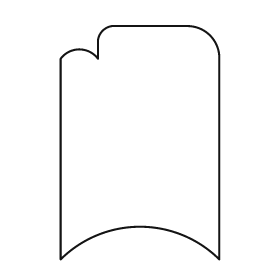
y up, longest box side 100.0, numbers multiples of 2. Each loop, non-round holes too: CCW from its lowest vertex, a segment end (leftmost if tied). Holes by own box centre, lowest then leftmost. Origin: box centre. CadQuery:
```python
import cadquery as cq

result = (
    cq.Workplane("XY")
    .moveTo(-34.0, -50.0)
    .threePointArc((0.0, -36.0), (34.0, -50.0))
    .lineTo(34.0, 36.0)
    .threePointArc((30.0, 46.0), (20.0, 50.0))
    .lineTo(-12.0, 50.0)
    .threePointArc((-16.0, 48.0), (-18.0, 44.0))
    .lineTo(-18.0, 36.0)
    .threePointArc((-26.0, 40.0), (-34.0, 36.0))
    .close()
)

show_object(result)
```